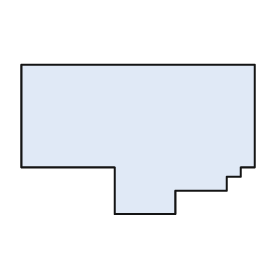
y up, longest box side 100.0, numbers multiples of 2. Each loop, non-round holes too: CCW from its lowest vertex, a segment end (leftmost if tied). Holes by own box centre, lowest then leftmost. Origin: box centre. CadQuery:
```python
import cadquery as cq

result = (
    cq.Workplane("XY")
    .moveTo(-10.0, -32.0)
    .lineTo(16.0, -32.0)
    .lineTo(16.0, -22.0)
    .lineTo(38.0, -22.0)
    .lineTo(38.0, -16.0)
    .lineTo(44.0, -16.0)
    .lineTo(44.0, -12.0)
    .lineTo(50.0, -12.0)
    .lineTo(50.0, 32.0)
    .lineTo(-50.0, 32.0)
    .lineTo(-50.0, -12.0)
    .lineTo(-10.0, -12.0)
    .close()
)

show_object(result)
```